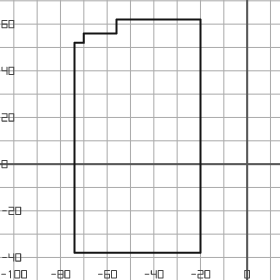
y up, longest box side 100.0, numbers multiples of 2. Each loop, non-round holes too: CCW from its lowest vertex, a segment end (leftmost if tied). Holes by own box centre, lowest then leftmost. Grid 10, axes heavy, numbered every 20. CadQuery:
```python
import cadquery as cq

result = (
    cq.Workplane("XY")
    .moveTo(-74.0, -38.0)
    .lineTo(-20.0, -38.0)
    .lineTo(-20.0, 62.0)
    .lineTo(-56.0, 62.0)
    .lineTo(-56.0, 56.0)
    .lineTo(-70.0, 56.0)
    .lineTo(-70.0, 52.0)
    .lineTo(-74.0, 52.0)
    .close()
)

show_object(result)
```